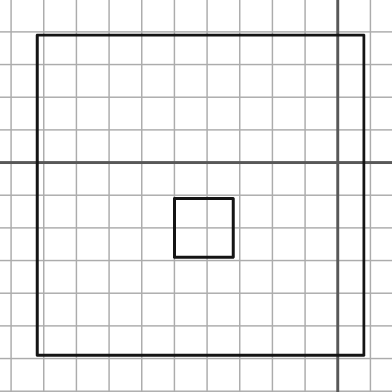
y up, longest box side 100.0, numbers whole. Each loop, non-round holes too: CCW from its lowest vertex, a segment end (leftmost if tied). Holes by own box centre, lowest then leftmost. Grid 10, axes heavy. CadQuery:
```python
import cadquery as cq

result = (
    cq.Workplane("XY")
    .moveTo(-92.0, -59.0)
    .lineTo(8.0, -59.0)
    .lineTo(8.0, 39.0)
    .lineTo(-92.0, 39.0)
    .close()
    .moveTo(-50.0, -29.0)
    .lineTo(-32.0, -29.0)
    .lineTo(-32.0, -11.0)
    .lineTo(-50.0, -11.0)
    .close()
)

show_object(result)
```